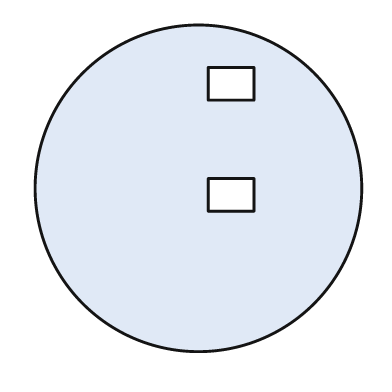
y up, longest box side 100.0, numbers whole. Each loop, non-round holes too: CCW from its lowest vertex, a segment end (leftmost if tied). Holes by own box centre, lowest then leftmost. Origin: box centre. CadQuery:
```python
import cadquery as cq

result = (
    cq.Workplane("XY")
    .moveTo(0.0, 0.0)
    .circle(50.0)
    .moveTo(3.0, -7.0)
    .lineTo(17.0, -7.0)
    .lineTo(17.0, 3.0)
    .lineTo(3.0, 3.0)
    .close()
    .moveTo(3.0, 27.0)
    .lineTo(17.0, 27.0)
    .lineTo(17.0, 37.0)
    .lineTo(3.0, 37.0)
    .close()
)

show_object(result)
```